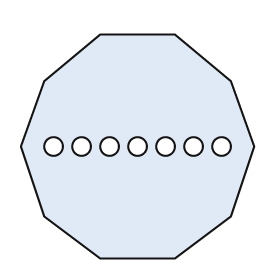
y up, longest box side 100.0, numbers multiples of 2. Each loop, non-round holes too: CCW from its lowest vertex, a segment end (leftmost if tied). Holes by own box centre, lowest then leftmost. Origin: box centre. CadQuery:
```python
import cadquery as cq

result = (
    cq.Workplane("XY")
    .moveTo(-16.0, -48.0)
    .lineTo(16.0, -48.0)
    .lineTo(40.0, -30.0)
    .lineTo(50.0, 0.0)
    .lineTo(40.0, 28.0)
    .lineTo(16.0, 48.0)
    .lineTo(-16.0, 48.0)
    .lineTo(-40.0, 28.0)
    .lineTo(-50.0, 0.0)
    .lineTo(-40.0, -30.0)
    .close()
    .moveTo(-36.0, 0.0)
    .circle(4.0)
    .moveTo(-24.0, 0.0)
    .circle(4.0)
    .moveTo(-12.0, 0.0)
    .circle(4.0)
    .moveTo(0.0, 0.0)
    .circle(4.0)
    .moveTo(12.0, 0.0)
    .circle(4.0)
    .moveTo(24.0, 0.0)
    .circle(4.0)
    .moveTo(36.0, 0.0)
    .circle(4.0)
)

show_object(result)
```